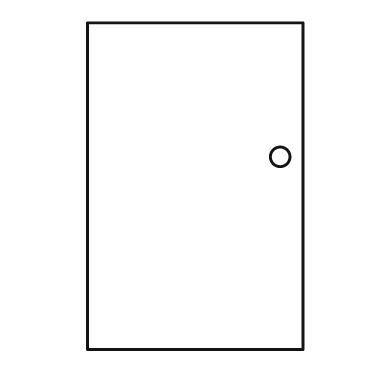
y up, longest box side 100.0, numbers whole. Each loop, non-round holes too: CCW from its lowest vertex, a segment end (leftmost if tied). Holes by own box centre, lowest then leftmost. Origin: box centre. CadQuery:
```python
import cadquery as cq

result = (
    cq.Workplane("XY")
    .moveTo(-33.0, -50.0)
    .lineTo(33.0, -50.0)
    .lineTo(33.0, 50.0)
    .lineTo(-33.0, 50.0)
    .close()
    .moveTo(26.0, 9.0)
    .circle(3.0)
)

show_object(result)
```